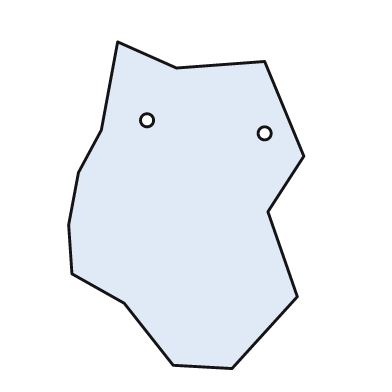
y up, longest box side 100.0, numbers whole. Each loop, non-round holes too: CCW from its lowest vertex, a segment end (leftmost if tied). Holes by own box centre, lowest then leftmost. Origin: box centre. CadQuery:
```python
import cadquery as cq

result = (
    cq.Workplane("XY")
    .moveTo(14.0, -50.0)
    .lineTo(34.0, -28.0)
    .lineTo(25.0, -2.0)
    .lineTo(36.0, 15.0)
    .lineTo(24.0, 44.0)
    .lineTo(-3.0, 42.0)
    .lineTo(-21.0, 50.0)
    .lineTo(-26.0, 23.0)
    .lineTo(-33.0, 10.0)
    .lineTo(-36.0, -6.0)
    .lineTo(-35.0, -21.0)
    .lineTo(-19.0, -30.0)
    .lineTo(-4.0, -49.0)
    .close()
    .moveTo(24.0, 22.0)
    .circle(2.0)
    .moveTo(-12.0, 26.0)
    .circle(2.0)
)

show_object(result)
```